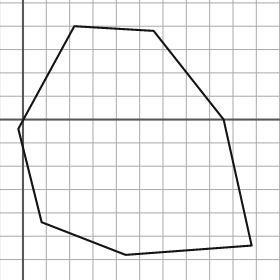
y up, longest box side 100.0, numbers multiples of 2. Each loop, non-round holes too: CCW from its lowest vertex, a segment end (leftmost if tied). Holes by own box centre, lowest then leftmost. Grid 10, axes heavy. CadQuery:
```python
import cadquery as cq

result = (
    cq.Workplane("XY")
    .moveTo(44.0, -58.0)
    .lineTo(98.0, -54.0)
    .lineTo(86.0, 0.0)
    .lineTo(56.0, 38.0)
    .lineTo(22.0, 40.0)
    .lineTo(-2.0, -4.0)
    .lineTo(8.0, -44.0)
    .close()
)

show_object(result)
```